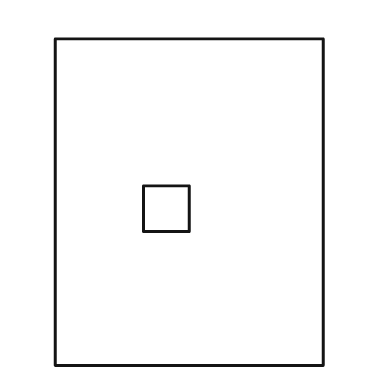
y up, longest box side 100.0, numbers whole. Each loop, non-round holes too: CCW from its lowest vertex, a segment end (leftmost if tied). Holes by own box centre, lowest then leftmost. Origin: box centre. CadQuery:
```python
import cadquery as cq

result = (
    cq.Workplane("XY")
    .moveTo(-41.0, -50.0)
    .lineTo(41.0, -50.0)
    .lineTo(41.0, 50.0)
    .lineTo(-41.0, 50.0)
    .close()
    .moveTo(-14.0, -9.0)
    .lineTo(0.0, -9.0)
    .lineTo(0.0, 5.0)
    .lineTo(-14.0, 5.0)
    .close()
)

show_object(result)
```